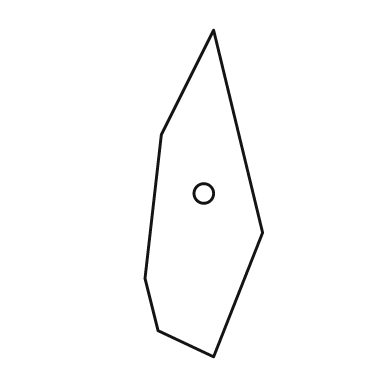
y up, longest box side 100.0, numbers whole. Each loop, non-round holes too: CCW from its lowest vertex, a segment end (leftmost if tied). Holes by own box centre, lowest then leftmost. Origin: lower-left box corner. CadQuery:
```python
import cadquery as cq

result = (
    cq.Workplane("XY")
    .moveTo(21.0, 0.0)
    .lineTo(36.0, 38.0)
    .lineTo(21.0, 100.0)
    .lineTo(5.0, 68.0)
    .lineTo(0.0, 24.0)
    .lineTo(4.0, 8.0)
    .close()
    .moveTo(18.0, 50.0)
    .circle(3.0)
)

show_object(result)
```